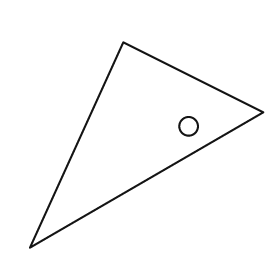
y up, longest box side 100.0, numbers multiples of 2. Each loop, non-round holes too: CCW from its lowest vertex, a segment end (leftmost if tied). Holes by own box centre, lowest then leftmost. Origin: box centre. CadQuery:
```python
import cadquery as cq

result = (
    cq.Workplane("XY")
    .moveTo(-50.0, -44.0)
    .lineTo(50.0, 14.0)
    .lineTo(-10.0, 44.0)
    .close()
    .moveTo(18.0, 8.0)
    .circle(4.0)
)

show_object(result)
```